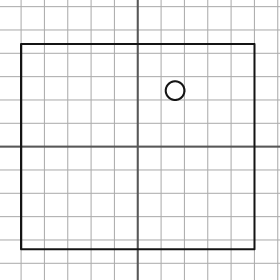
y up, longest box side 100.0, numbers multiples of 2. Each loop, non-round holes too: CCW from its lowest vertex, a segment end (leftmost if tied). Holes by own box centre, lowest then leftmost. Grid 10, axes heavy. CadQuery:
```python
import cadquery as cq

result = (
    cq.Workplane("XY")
    .moveTo(-50.0, -44.0)
    .lineTo(50.0, -44.0)
    .lineTo(50.0, 44.0)
    .lineTo(-50.0, 44.0)
    .close()
    .moveTo(16.0, 24.0)
    .circle(4.0)
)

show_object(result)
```